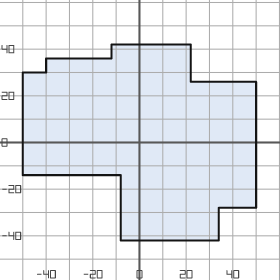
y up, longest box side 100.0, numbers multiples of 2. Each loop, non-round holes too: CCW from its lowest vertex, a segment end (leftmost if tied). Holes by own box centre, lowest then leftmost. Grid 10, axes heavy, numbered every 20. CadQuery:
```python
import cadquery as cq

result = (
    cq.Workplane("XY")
    .moveTo(-8.0, -42.0)
    .lineTo(34.0, -42.0)
    .lineTo(34.0, -28.0)
    .lineTo(50.0, -28.0)
    .lineTo(50.0, 26.0)
    .lineTo(22.0, 26.0)
    .lineTo(22.0, 42.0)
    .lineTo(-12.0, 42.0)
    .lineTo(-12.0, 36.0)
    .lineTo(-40.0, 36.0)
    .lineTo(-40.0, 30.0)
    .lineTo(-50.0, 30.0)
    .lineTo(-50.0, -14.0)
    .lineTo(-8.0, -14.0)
    .close()
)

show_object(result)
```